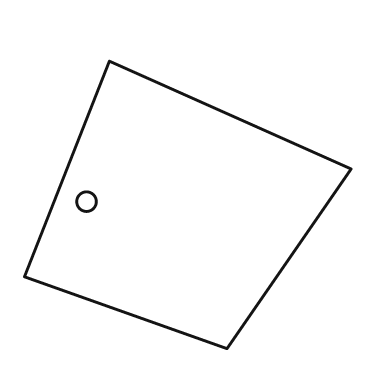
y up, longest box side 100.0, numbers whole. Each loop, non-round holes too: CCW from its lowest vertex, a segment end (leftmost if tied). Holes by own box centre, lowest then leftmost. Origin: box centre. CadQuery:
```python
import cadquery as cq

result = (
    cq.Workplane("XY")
    .moveTo(12.0, -44.0)
    .lineTo(50.0, 11.0)
    .lineTo(-24.0, 44.0)
    .lineTo(-50.0, -22.0)
    .close()
    .moveTo(-31.0, 1.0)
    .circle(3.0)
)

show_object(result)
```